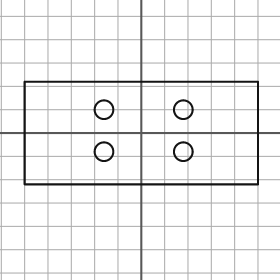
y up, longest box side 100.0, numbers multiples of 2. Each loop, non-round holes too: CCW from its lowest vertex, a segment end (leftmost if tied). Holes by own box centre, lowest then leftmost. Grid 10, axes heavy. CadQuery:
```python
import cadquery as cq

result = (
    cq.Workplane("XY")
    .moveTo(-50.0, -22.0)
    .lineTo(50.0, -22.0)
    .lineTo(50.0, 22.0)
    .lineTo(-50.0, 22.0)
    .close()
    .moveTo(-16.0, -8.0)
    .circle(4.0)
    .moveTo(18.0, -8.0)
    .circle(4.0)
    .moveTo(-16.0, 10.0)
    .circle(4.0)
    .moveTo(18.0, 10.0)
    .circle(4.0)
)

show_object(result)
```